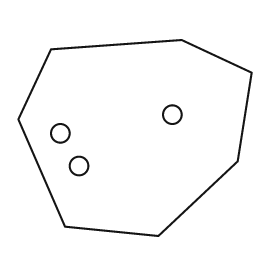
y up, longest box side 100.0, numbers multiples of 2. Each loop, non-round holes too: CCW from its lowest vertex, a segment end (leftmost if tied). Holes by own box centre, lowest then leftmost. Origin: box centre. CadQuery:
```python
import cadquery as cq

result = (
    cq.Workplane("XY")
    .moveTo(10.0, -42.0)
    .lineTo(44.0, -10.0)
    .lineTo(50.0, 28.0)
    .lineTo(20.0, 42.0)
    .lineTo(-36.0, 38.0)
    .lineTo(-50.0, 8.0)
    .lineTo(-30.0, -38.0)
    .close()
    .moveTo(-24.0, -12.0)
    .circle(4.0)
    .moveTo(-32.0, 2.0)
    .circle(4.0)
    .moveTo(16.0, 10.0)
    .circle(4.0)
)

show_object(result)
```